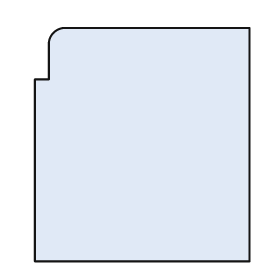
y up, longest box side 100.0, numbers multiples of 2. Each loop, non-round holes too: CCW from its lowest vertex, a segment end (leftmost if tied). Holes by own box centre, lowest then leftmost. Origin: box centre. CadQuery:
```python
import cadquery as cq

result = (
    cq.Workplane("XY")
    .moveTo(-46.0, -50.0)
    .lineTo(46.0, -50.0)
    .lineTo(46.0, 50.0)
    .lineTo(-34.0, 50.0)
    .threePointArc((-38.0, 48.0), (-40.0, 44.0))
    .lineTo(-40.0, 28.0)
    .lineTo(-46.0, 28.0)
    .close()
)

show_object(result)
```